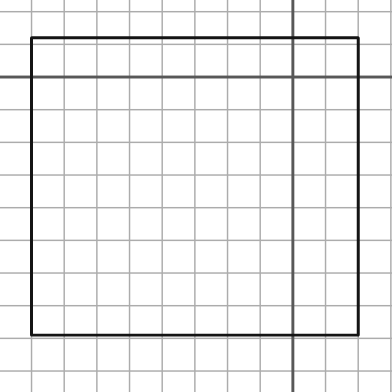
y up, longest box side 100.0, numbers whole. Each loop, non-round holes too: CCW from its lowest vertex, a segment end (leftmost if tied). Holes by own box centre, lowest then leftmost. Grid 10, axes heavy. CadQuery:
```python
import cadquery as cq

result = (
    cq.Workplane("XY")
    .moveTo(-80.0, -79.0)
    .lineTo(20.0, -79.0)
    .lineTo(20.0, 12.0)
    .lineTo(-80.0, 12.0)
    .close()
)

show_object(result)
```